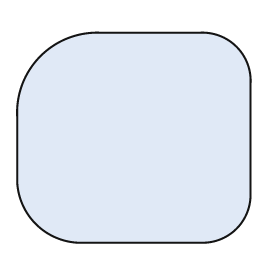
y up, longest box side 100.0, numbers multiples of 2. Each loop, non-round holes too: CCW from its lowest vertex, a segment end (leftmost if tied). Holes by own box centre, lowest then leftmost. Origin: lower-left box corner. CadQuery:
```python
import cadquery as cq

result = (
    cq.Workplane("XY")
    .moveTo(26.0, 0.0)
    .lineTo(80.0, 0.0)
    .threePointArc((94.0, 6.0), (100.0, 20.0))
    .lineTo(100.0, 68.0)
    .threePointArc((94.0, 84.0), (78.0, 90.0))
    .lineTo(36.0, 90.0)
    .threePointArc((10.0, 80.0), (0.0, 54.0))
    .lineTo(0.0, 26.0)
    .threePointArc((8.0, 8.0), (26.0, 0.0))
    .close()
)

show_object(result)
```